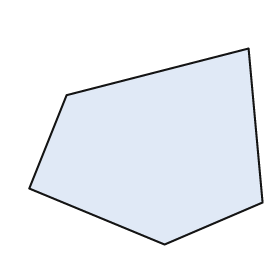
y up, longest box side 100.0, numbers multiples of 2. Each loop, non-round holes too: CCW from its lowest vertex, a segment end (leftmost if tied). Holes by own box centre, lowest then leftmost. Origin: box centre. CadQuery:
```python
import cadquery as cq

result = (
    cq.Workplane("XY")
    .moveTo(8.0, -42.0)
    .lineTo(50.0, -24.0)
    .lineTo(44.0, 42.0)
    .lineTo(-34.0, 22.0)
    .lineTo(-50.0, -18.0)
    .close()
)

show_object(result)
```